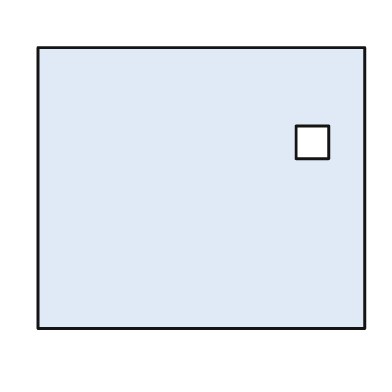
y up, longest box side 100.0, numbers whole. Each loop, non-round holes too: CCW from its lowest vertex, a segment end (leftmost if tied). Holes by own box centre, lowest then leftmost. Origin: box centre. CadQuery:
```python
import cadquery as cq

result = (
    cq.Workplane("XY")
    .moveTo(-50.0, -43.0)
    .lineTo(50.0, -43.0)
    .lineTo(50.0, 43.0)
    .lineTo(-50.0, 43.0)
    .close()
    .moveTo(29.0, 9.0)
    .lineTo(39.0, 9.0)
    .lineTo(39.0, 19.0)
    .lineTo(29.0, 19.0)
    .close()
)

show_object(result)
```